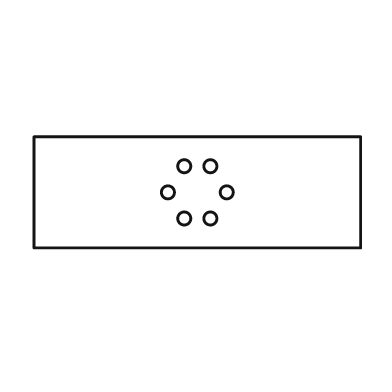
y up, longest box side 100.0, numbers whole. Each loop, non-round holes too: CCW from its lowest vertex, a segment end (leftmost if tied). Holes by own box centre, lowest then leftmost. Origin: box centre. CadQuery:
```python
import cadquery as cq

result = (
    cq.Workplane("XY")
    .moveTo(-50.0, -17.0)
    .lineTo(50.0, -17.0)
    .lineTo(50.0, 17.0)
    .lineTo(-50.0, 17.0)
    .close()
    .moveTo(-4.0, -8.0)
    .circle(2.0)
    .moveTo(4.0, -8.0)
    .circle(2.0)
    .moveTo(-9.0, 0.0)
    .circle(2.0)
    .moveTo(9.0, 0.0)
    .circle(2.0)
    .moveTo(-4.0, 8.0)
    .circle(2.0)
    .moveTo(4.0, 8.0)
    .circle(2.0)
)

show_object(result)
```